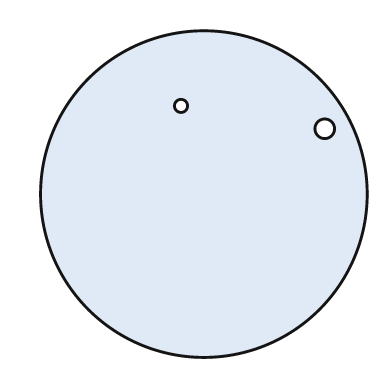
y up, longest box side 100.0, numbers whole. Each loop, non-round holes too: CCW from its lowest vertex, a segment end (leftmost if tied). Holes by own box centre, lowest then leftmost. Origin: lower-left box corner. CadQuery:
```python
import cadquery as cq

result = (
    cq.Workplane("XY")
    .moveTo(50.0, 50.0)
    .circle(50.0)
    .moveTo(87.0, 70.0)
    .circle(3.0)
    .moveTo(43.0, 77.0)
    .circle(2.0)
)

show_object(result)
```